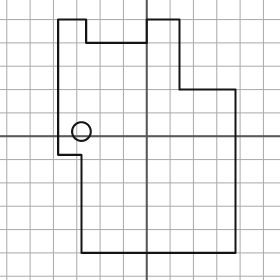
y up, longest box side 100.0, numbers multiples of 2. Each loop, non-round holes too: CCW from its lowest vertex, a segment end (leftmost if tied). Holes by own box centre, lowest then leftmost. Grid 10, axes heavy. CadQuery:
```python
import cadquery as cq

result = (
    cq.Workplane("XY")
    .moveTo(-28.0, -50.0)
    .lineTo(38.0, -50.0)
    .lineTo(38.0, 20.0)
    .lineTo(14.0, 20.0)
    .lineTo(14.0, 50.0)
    .lineTo(0.0, 50.0)
    .lineTo(0.0, 40.0)
    .lineTo(-26.0, 40.0)
    .lineTo(-26.0, 50.0)
    .lineTo(-38.0, 50.0)
    .lineTo(-38.0, -8.0)
    .lineTo(-28.0, -8.0)
    .close()
    .moveTo(-28.0, 2.0)
    .circle(4.0)
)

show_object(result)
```